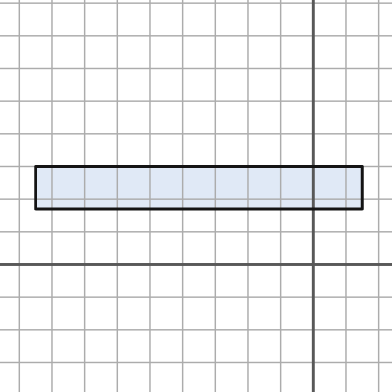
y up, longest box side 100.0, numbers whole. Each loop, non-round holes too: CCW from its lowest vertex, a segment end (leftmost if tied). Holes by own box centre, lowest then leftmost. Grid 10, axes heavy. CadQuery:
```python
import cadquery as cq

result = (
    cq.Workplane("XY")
    .moveTo(-85.0, 17.0)
    .lineTo(15.0, 17.0)
    .lineTo(15.0, 30.0)
    .lineTo(-85.0, 30.0)
    .close()
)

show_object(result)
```